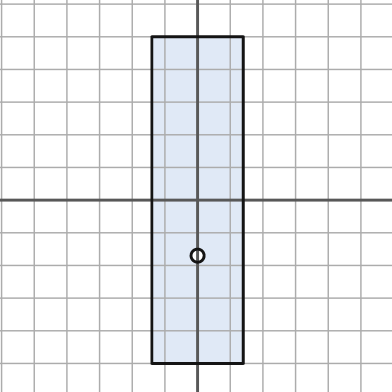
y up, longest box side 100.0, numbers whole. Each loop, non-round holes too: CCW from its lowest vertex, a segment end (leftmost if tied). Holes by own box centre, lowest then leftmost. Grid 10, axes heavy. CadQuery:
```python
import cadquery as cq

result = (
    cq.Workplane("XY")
    .moveTo(-14.0, -50.0)
    .lineTo(14.0, -50.0)
    .lineTo(14.0, 50.0)
    .lineTo(-14.0, 50.0)
    .close()
    .moveTo(0.0, -17.0)
    .circle(2.0)
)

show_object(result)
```